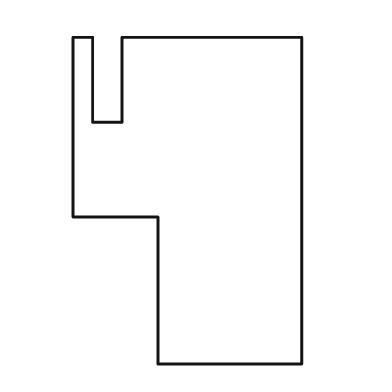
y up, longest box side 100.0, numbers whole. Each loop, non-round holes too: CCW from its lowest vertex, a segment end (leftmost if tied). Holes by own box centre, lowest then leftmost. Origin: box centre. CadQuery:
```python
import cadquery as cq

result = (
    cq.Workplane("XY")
    .moveTo(-9.0, -50.0)
    .lineTo(35.0, -50.0)
    .lineTo(35.0, 50.0)
    .lineTo(-20.0, 50.0)
    .lineTo(-20.0, 24.0)
    .lineTo(-29.0, 24.0)
    .lineTo(-29.0, 50.0)
    .lineTo(-35.0, 50.0)
    .lineTo(-35.0, -5.0)
    .lineTo(-9.0, -5.0)
    .close()
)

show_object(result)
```